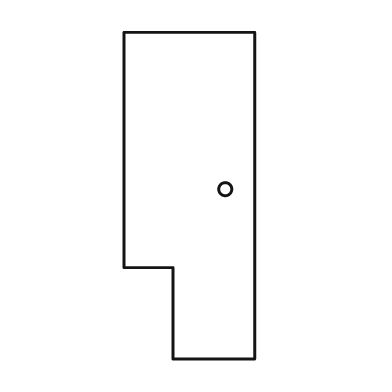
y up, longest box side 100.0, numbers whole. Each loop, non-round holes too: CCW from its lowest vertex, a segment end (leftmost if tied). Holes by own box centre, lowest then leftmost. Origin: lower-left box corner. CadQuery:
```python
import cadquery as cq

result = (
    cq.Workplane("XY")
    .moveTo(15.0, 0.0)
    .lineTo(40.0, 0.0)
    .lineTo(40.0, 100.0)
    .lineTo(0.0, 100.0)
    .lineTo(0.0, 28.0)
    .lineTo(15.0, 28.0)
    .close()
    .moveTo(31.0, 52.0)
    .circle(2.0)
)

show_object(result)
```